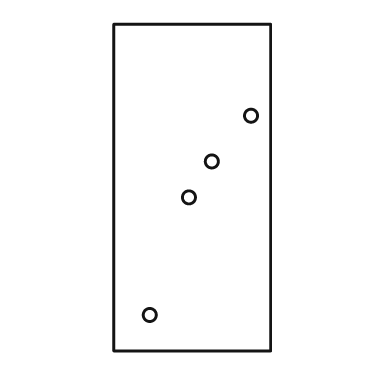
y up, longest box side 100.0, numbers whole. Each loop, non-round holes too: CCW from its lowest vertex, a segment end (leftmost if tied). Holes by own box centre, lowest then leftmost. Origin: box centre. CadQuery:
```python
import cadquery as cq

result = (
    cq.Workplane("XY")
    .moveTo(-24.0, -50.0)
    .lineTo(24.0, -50.0)
    .lineTo(24.0, 50.0)
    .lineTo(-24.0, 50.0)
    .close()
    .moveTo(-13.0, -39.0)
    .circle(2.0)
    .moveTo(-1.0, -3.0)
    .circle(2.0)
    .moveTo(6.0, 8.0)
    .circle(2.0)
    .moveTo(18.0, 22.0)
    .circle(2.0)
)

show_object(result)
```